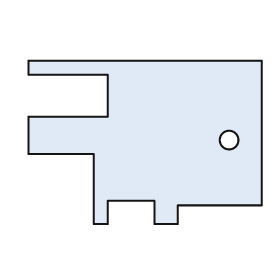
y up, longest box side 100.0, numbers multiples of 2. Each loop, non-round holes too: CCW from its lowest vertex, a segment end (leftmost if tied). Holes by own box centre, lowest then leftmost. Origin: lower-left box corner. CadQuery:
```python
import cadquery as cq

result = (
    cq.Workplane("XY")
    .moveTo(28.0, 0.0)
    .lineTo(34.0, 0.0)
    .lineTo(34.0, 10.0)
    .lineTo(54.0, 10.0)
    .lineTo(54.0, 0.0)
    .lineTo(64.0, 0.0)
    .lineTo(64.0, 8.0)
    .lineTo(100.0, 8.0)
    .lineTo(100.0, 70.0)
    .lineTo(0.0, 70.0)
    .lineTo(0.0, 64.0)
    .lineTo(34.0, 64.0)
    .lineTo(34.0, 46.0)
    .lineTo(0.0, 46.0)
    .lineTo(0.0, 30.0)
    .lineTo(28.0, 30.0)
    .close()
    .moveTo(86.0, 36.0)
    .circle(4.0)
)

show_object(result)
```